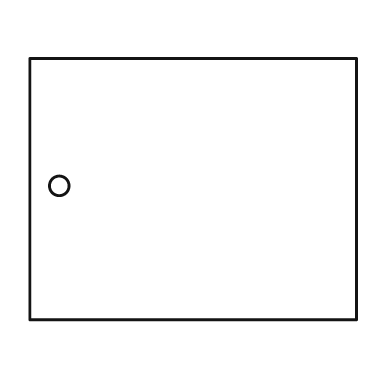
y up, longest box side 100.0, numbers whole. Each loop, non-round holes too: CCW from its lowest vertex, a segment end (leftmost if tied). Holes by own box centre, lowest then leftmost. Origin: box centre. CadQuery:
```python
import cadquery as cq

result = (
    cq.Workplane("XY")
    .moveTo(-50.0, -40.0)
    .lineTo(50.0, -40.0)
    .lineTo(50.0, 40.0)
    .lineTo(-50.0, 40.0)
    .close()
    .moveTo(-41.0, 1.0)
    .circle(3.0)
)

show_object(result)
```